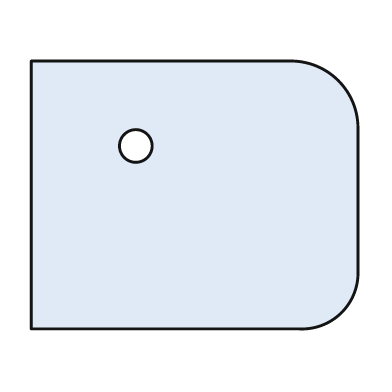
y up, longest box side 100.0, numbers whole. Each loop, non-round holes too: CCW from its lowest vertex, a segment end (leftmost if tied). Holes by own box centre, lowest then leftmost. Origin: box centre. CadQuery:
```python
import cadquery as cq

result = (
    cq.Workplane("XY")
    .moveTo(-50.0, -41.0)
    .lineTo(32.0, -41.0)
    .threePointArc((45.0, -36.0), (50.0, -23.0))
    .lineTo(50.0, 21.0)
    .threePointArc((44.0, 35.0), (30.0, 41.0))
    .lineTo(-50.0, 41.0)
    .close()
    .moveTo(-18.0, 15.0)
    .circle(5.0)
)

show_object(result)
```